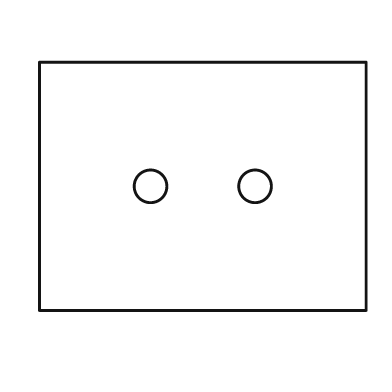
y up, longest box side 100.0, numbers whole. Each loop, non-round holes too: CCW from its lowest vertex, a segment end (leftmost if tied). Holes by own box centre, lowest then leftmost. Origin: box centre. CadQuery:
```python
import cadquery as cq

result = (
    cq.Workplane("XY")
    .moveTo(-50.0, -38.0)
    .lineTo(50.0, -38.0)
    .lineTo(50.0, 38.0)
    .lineTo(-50.0, 38.0)
    .close()
    .moveTo(-16.0, 0.0)
    .circle(5.0)
    .moveTo(16.0, 0.0)
    .circle(5.0)
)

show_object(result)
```